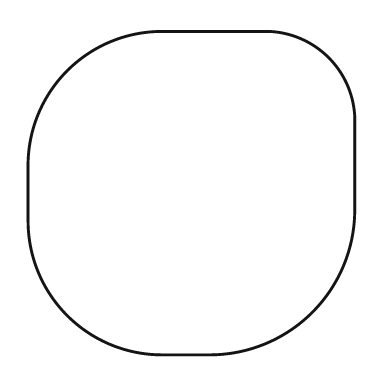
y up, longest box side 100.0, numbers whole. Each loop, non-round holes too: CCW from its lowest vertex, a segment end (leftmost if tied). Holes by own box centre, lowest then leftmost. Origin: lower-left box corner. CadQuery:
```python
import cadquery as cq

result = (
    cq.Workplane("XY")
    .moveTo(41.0, 0.0)
    .lineTo(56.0, 0.0)
    .threePointArc((87.0, 13.0), (100.0, 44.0))
    .lineTo(100.0, 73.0)
    .threePointArc((92.0, 91.0), (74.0, 99.0))
    .lineTo(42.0, 99.0)
    .threePointArc((12.0, 87.0), (0.0, 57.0))
    .lineTo(0.0, 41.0)
    .threePointArc((12.0, 12.0), (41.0, 0.0))
    .close()
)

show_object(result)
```